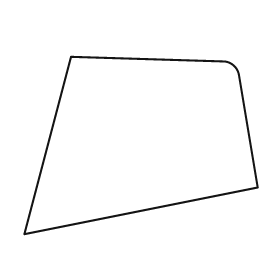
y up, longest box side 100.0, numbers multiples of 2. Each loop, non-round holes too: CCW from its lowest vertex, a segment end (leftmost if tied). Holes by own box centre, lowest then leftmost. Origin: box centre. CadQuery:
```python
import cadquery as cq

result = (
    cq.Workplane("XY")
    .moveTo(-50.0, -38.0)
    .lineTo(50.0, -18.0)
    .lineTo(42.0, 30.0)
    .threePointArc((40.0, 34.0), (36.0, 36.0))
    .lineTo(-30.0, 38.0)
    .close()
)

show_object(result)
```